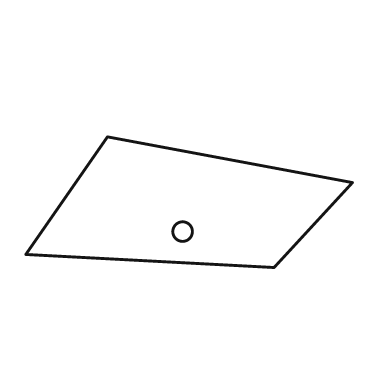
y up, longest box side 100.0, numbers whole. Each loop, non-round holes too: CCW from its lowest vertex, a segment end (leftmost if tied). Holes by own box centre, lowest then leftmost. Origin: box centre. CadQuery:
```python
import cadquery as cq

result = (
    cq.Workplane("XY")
    .moveTo(26.0, -20.0)
    .lineTo(50.0, 6.0)
    .lineTo(-25.0, 20.0)
    .lineTo(-50.0, -16.0)
    .close()
    .moveTo(-2.0, -9.0)
    .circle(3.0)
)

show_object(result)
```